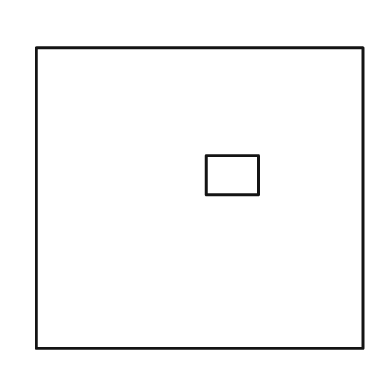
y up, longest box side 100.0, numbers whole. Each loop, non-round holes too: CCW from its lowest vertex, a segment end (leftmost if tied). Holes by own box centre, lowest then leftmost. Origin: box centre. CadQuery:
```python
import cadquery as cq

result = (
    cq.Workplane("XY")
    .moveTo(-50.0, -46.0)
    .lineTo(50.0, -46.0)
    .lineTo(50.0, 46.0)
    .lineTo(-50.0, 46.0)
    .close()
    .moveTo(2.0, 1.0)
    .lineTo(18.0, 1.0)
    .lineTo(18.0, 13.0)
    .lineTo(2.0, 13.0)
    .close()
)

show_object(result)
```